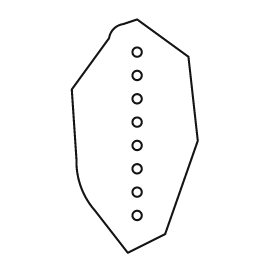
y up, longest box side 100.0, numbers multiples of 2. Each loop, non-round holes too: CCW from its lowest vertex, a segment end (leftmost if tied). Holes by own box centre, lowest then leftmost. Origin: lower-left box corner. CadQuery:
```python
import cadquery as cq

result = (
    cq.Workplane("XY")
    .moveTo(24.0, 0.0)
    .lineTo(40.0, 8.0)
    .lineTo(54.0, 48.0)
    .lineTo(50.0, 84.0)
    .lineTo(28.0, 100.0)
    .lineTo(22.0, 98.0)
    .threePointArc((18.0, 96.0), (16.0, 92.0))
    .lineTo(0.0, 70.0)
    .lineTo(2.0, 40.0)
    .threePointArc((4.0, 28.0), (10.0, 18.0))
    .close()
    .moveTo(28.0, 16.0)
    .circle(2.0)
    .moveTo(28.0, 26.0)
    .circle(2.0)
    .moveTo(28.0, 36.0)
    .circle(2.0)
    .moveTo(28.0, 46.0)
    .circle(2.0)
    .moveTo(28.0, 56.0)
    .circle(2.0)
    .moveTo(28.0, 66.0)
    .circle(2.0)
    .moveTo(28.0, 76.0)
    .circle(2.0)
    .moveTo(28.0, 86.0)
    .circle(2.0)
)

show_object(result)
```